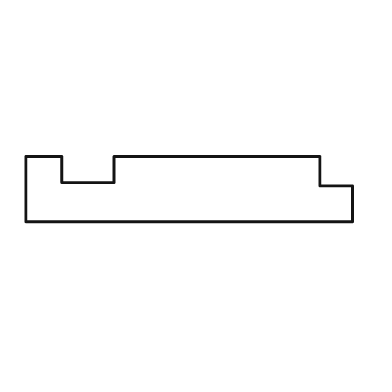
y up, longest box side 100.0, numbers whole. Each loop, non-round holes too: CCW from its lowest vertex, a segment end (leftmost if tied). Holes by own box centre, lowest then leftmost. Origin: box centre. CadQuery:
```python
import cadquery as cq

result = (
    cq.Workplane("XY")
    .moveTo(-50.0, -10.0)
    .lineTo(50.0, -10.0)
    .lineTo(50.0, 1.0)
    .lineTo(40.0, 1.0)
    .lineTo(40.0, 10.0)
    .lineTo(-23.0, 10.0)
    .lineTo(-23.0, 2.0)
    .lineTo(-39.0, 2.0)
    .lineTo(-39.0, 10.0)
    .lineTo(-50.0, 10.0)
    .close()
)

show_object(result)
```